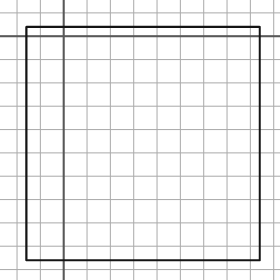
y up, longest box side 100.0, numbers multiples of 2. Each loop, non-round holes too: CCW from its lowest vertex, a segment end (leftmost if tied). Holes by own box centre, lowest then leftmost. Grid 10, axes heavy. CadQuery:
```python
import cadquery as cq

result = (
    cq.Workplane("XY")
    .moveTo(-16.0, -96.0)
    .lineTo(84.0, -96.0)
    .lineTo(84.0, 4.0)
    .lineTo(-16.0, 4.0)
    .close()
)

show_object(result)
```